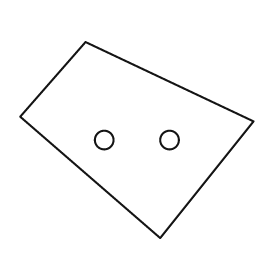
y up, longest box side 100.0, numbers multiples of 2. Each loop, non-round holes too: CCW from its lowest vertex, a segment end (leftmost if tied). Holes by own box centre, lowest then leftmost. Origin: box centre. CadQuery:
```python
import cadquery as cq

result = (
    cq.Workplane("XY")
    .moveTo(10.0, -42.0)
    .lineTo(50.0, 8.0)
    .lineTo(-22.0, 42.0)
    .lineTo(-50.0, 10.0)
    .close()
    .moveTo(-14.0, 0.0)
    .circle(4.0)
    .moveTo(14.0, 0.0)
    .circle(4.0)
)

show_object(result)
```